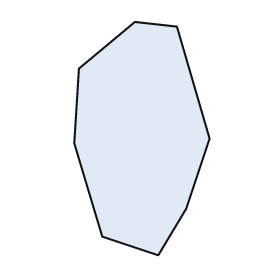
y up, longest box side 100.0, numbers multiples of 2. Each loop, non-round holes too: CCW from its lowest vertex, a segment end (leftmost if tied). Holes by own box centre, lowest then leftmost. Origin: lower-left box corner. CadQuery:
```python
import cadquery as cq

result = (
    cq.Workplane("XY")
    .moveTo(36.0, 0.0)
    .lineTo(48.0, 20.0)
    .lineTo(58.0, 50.0)
    .lineTo(44.0, 98.0)
    .lineTo(26.0, 100.0)
    .lineTo(2.0, 80.0)
    .lineTo(0.0, 48.0)
    .lineTo(12.0, 8.0)
    .close()
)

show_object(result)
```